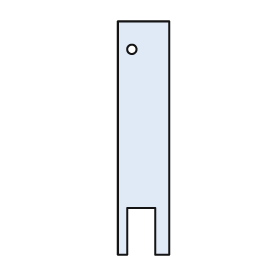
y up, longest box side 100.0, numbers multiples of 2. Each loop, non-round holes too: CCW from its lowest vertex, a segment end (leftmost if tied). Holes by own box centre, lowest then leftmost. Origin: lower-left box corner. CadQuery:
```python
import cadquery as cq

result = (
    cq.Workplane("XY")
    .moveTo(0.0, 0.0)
    .lineTo(4.0, 0.0)
    .lineTo(4.0, 20.0)
    .lineTo(16.0, 20.0)
    .lineTo(16.0, 0.0)
    .lineTo(22.0, 0.0)
    .lineTo(22.0, 100.0)
    .lineTo(0.0, 100.0)
    .close()
    .moveTo(6.0, 88.0)
    .circle(2.0)
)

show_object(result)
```